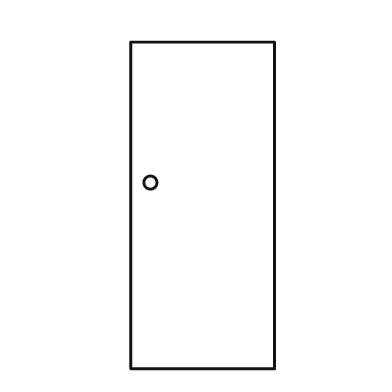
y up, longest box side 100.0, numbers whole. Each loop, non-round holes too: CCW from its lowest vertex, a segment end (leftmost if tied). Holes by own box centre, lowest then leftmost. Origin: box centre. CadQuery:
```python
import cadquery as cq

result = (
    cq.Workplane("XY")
    .moveTo(-22.0, -50.0)
    .lineTo(22.0, -50.0)
    .lineTo(22.0, 50.0)
    .lineTo(-22.0, 50.0)
    .close()
    .moveTo(-16.0, 7.0)
    .circle(2.0)
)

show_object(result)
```